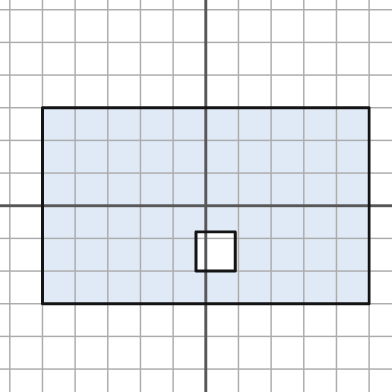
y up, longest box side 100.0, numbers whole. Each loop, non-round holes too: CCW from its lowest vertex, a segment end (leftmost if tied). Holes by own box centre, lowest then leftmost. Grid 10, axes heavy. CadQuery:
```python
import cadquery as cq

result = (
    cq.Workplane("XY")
    .moveTo(-50.0, -30.0)
    .lineTo(50.0, -30.0)
    .lineTo(50.0, 30.0)
    .lineTo(-50.0, 30.0)
    .close()
    .moveTo(-3.0, -20.0)
    .lineTo(9.0, -20.0)
    .lineTo(9.0, -8.0)
    .lineTo(-3.0, -8.0)
    .close()
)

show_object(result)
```